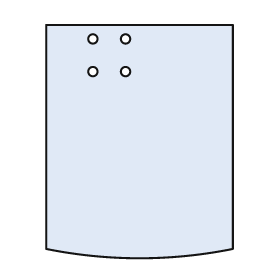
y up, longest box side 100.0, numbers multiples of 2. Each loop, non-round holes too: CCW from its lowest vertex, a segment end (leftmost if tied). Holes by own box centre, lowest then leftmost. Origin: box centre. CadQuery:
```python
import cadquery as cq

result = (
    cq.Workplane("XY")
    .moveTo(-40.0, -46.0)
    .threePointArc((0.0, -50.0), (40.0, -46.0))
    .lineTo(40.0, 50.0)
    .lineTo(-40.0, 50.0)
    .close()
    .moveTo(-20.0, 30.0)
    .circle(2.0)
    .moveTo(-6.0, 30.0)
    .circle(2.0)
    .moveTo(-20.0, 44.0)
    .circle(2.0)
    .moveTo(-6.0, 44.0)
    .circle(2.0)
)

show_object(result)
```